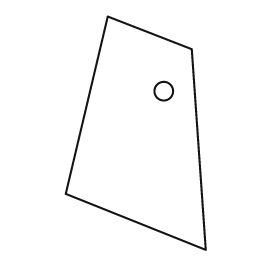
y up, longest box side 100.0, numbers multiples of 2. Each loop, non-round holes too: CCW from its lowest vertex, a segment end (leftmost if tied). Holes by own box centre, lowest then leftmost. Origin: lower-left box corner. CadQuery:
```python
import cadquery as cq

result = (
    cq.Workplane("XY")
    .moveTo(60.0, 0.0)
    .lineTo(54.0, 86.0)
    .lineTo(18.0, 100.0)
    .lineTo(0.0, 24.0)
    .close()
    .moveTo(42.0, 68.0)
    .circle(4.0)
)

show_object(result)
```